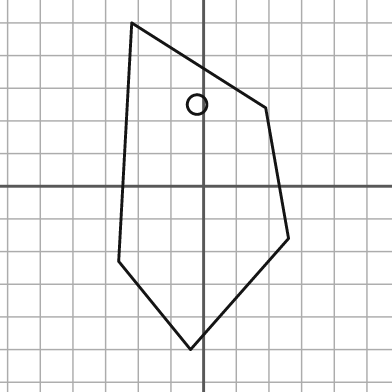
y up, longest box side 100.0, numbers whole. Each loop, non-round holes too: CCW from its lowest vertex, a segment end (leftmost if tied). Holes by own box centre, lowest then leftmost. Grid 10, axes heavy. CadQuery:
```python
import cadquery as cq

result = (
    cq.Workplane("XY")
    .moveTo(-4.0, -50.0)
    .lineTo(26.0, -16.0)
    .lineTo(19.0, 24.0)
    .lineTo(-22.0, 50.0)
    .lineTo(-26.0, -23.0)
    .close()
    .moveTo(-2.0, 25.0)
    .circle(3.0)
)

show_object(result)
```